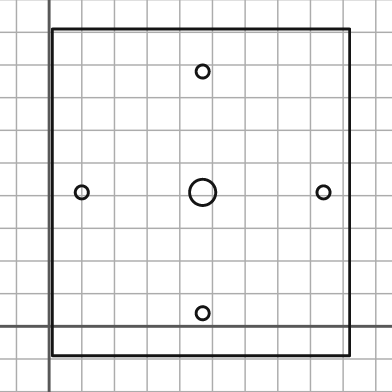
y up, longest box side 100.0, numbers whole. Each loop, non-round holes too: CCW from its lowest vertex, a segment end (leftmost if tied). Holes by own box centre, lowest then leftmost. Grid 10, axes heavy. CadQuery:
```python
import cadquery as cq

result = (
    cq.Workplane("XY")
    .moveTo(1.0, -9.0)
    .lineTo(92.0, -9.0)
    .lineTo(92.0, 91.0)
    .lineTo(1.0, 91.0)
    .close()
    .moveTo(47.0, 4.0)
    .circle(2.0)
    .moveTo(10.0, 41.0)
    .circle(2.0)
    .moveTo(47.0, 41.0)
    .circle(4.0)
    .moveTo(84.0, 41.0)
    .circle(2.0)
    .moveTo(47.0, 78.0)
    .circle(2.0)
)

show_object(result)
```